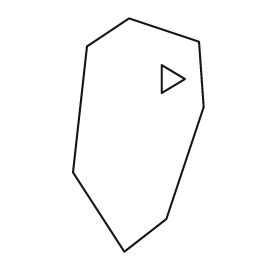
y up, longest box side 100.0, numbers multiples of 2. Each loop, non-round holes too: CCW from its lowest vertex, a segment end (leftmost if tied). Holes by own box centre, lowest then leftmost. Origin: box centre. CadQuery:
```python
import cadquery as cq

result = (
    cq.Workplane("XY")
    .moveTo(-6.0, -50.0)
    .lineTo(12.0, -36.0)
    .lineTo(28.0, 12.0)
    .lineTo(26.0, 40.0)
    .lineTo(-4.0, 50.0)
    .lineTo(-22.0, 38.0)
    .lineTo(-28.0, -16.0)
    .close()
    .moveTo(10.0, 18.0)
    .lineTo(20.0, 24.0)
    .lineTo(10.0, 30.0)
    .close()
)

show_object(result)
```